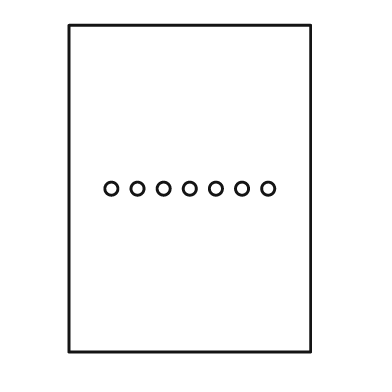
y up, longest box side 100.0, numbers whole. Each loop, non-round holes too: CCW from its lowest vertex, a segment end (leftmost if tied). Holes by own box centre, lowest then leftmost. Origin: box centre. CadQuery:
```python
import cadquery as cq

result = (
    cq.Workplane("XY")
    .moveTo(-37.0, -50.0)
    .lineTo(37.0, -50.0)
    .lineTo(37.0, 50.0)
    .lineTo(-37.0, 50.0)
    .close()
    .moveTo(-24.0, 0.0)
    .circle(2.0)
    .moveTo(-16.0, 0.0)
    .circle(2.0)
    .moveTo(-8.0, 0.0)
    .circle(2.0)
    .moveTo(0.0, 0.0)
    .circle(2.0)
    .moveTo(8.0, 0.0)
    .circle(2.0)
    .moveTo(16.0, 0.0)
    .circle(2.0)
    .moveTo(24.0, 0.0)
    .circle(2.0)
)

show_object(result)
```